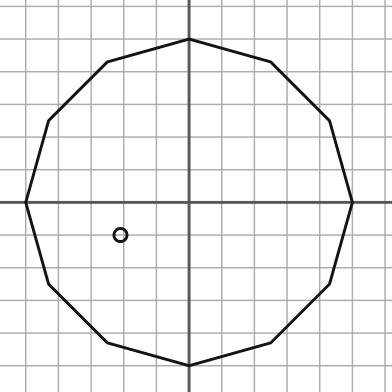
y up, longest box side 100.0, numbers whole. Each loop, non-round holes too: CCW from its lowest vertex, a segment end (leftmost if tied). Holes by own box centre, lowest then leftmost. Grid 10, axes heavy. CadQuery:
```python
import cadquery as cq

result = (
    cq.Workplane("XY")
    .moveTo(0.0, -50.0)
    .lineTo(25.0, -43.0)
    .lineTo(43.0, -25.0)
    .lineTo(50.0, 0.0)
    .lineTo(43.0, 25.0)
    .lineTo(25.0, 43.0)
    .lineTo(0.0, 50.0)
    .lineTo(-25.0, 43.0)
    .lineTo(-43.0, 25.0)
    .lineTo(-50.0, 0.0)
    .lineTo(-43.0, -25.0)
    .lineTo(-25.0, -43.0)
    .close()
    .moveTo(-21.0, -10.0)
    .circle(2.0)
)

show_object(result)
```